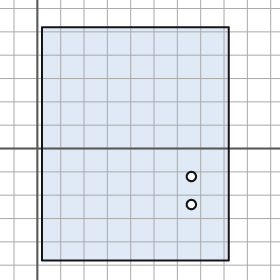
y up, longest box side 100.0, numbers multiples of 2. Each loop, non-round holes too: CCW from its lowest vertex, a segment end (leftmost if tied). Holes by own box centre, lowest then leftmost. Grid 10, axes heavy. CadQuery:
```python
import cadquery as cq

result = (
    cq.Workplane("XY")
    .moveTo(2.0, -48.0)
    .lineTo(82.0, -48.0)
    .lineTo(82.0, 52.0)
    .lineTo(2.0, 52.0)
    .close()
    .moveTo(66.0, -24.0)
    .circle(2.0)
    .moveTo(66.0, -12.0)
    .circle(2.0)
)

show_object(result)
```